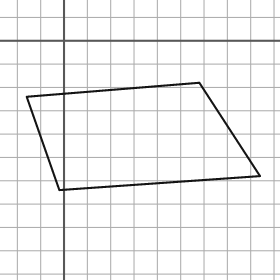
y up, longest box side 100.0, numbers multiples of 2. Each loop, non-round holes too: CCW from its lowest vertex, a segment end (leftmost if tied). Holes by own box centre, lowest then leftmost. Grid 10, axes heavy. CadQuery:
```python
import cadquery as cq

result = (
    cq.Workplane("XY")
    .moveTo(-2.0, -64.0)
    .lineTo(84.0, -58.0)
    .lineTo(58.0, -18.0)
    .lineTo(-16.0, -24.0)
    .close()
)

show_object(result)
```